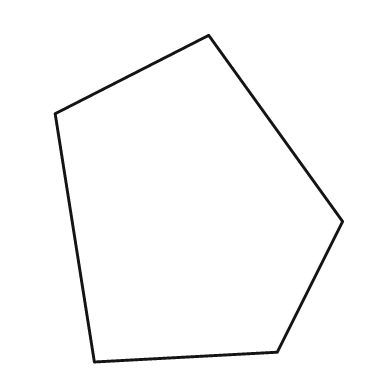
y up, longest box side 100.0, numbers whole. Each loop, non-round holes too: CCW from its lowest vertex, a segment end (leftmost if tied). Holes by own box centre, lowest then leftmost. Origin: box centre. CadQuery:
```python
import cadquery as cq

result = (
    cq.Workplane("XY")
    .moveTo(-32.0, -50.0)
    .lineTo(24.0, -47.0)
    .lineTo(44.0, -7.0)
    .lineTo(3.0, 50.0)
    .lineTo(-44.0, 26.0)
    .close()
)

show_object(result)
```